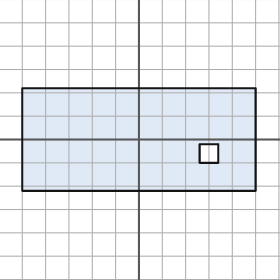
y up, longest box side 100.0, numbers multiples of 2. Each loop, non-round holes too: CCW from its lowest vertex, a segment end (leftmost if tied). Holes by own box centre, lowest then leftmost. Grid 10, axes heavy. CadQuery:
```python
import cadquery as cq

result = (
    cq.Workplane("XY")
    .moveTo(-50.0, -22.0)
    .lineTo(50.0, -22.0)
    .lineTo(50.0, 22.0)
    .lineTo(-50.0, 22.0)
    .close()
    .moveTo(26.0, -10.0)
    .lineTo(34.0, -10.0)
    .lineTo(34.0, -2.0)
    .lineTo(26.0, -2.0)
    .close()
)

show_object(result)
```